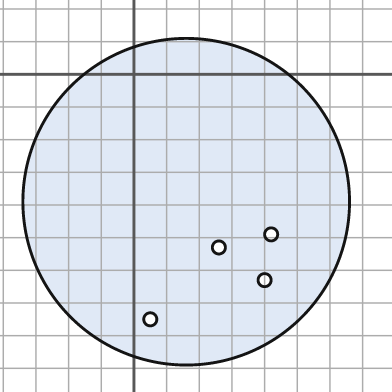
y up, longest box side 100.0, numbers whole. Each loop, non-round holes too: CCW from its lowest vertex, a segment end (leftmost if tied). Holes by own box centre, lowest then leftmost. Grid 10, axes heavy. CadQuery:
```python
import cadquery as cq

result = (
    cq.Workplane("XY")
    .moveTo(16.0, -39.0)
    .circle(50.0)
    .moveTo(5.0, -75.0)
    .circle(2.0)
    .moveTo(40.0, -63.0)
    .circle(2.0)
    .moveTo(26.0, -53.0)
    .circle(2.0)
    .moveTo(42.0, -49.0)
    .circle(2.0)
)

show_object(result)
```